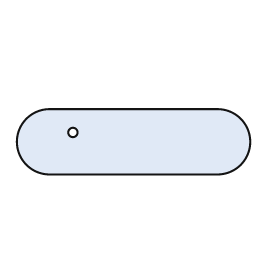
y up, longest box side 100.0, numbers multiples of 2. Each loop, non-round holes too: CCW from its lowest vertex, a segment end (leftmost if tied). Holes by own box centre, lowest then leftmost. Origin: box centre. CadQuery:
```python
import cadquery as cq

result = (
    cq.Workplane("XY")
    .moveTo(-36.0, -14.0)
    .lineTo(36.0, -14.0)
    .threePointArc((50.0, 0.0), (36.0, 14.0))
    .lineTo(-36.0, 14.0)
    .threePointArc((-50.0, 0.0), (-36.0, -14.0))
    .close()
    .moveTo(-26.0, 4.0)
    .circle(2.0)
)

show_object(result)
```